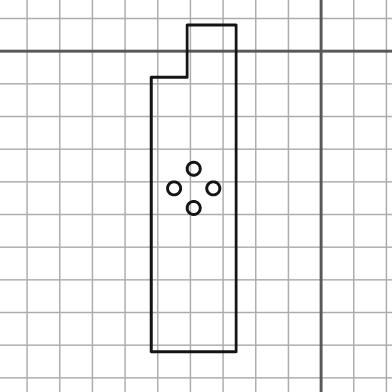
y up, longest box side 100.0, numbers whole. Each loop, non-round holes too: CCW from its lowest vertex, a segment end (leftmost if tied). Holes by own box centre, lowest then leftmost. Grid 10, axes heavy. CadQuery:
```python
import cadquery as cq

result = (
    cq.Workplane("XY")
    .moveTo(-52.0, -92.0)
    .lineTo(-26.0, -92.0)
    .lineTo(-26.0, 8.0)
    .lineTo(-41.0, 8.0)
    .lineTo(-41.0, -8.0)
    .lineTo(-52.0, -8.0)
    .close()
    .moveTo(-39.0, -48.0)
    .circle(2.0)
    .moveTo(-45.0, -42.0)
    .circle(2.0)
    .moveTo(-33.0, -42.0)
    .circle(2.0)
    .moveTo(-39.0, -36.0)
    .circle(2.0)
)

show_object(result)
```